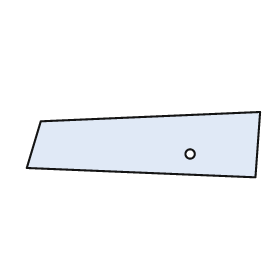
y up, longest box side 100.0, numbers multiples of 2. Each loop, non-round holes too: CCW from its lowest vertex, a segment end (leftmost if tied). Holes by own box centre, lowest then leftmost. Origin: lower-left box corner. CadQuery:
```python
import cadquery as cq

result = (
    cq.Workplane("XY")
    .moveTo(98.0, 0.0)
    .lineTo(100.0, 28.0)
    .lineTo(6.0, 24.0)
    .lineTo(0.0, 4.0)
    .close()
    .moveTo(70.0, 10.0)
    .circle(2.0)
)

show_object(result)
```